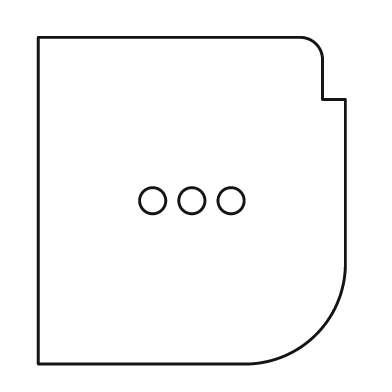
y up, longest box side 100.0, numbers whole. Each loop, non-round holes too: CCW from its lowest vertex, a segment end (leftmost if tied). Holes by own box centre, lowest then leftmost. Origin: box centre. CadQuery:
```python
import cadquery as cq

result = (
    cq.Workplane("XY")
    .moveTo(-47.0, -50.0)
    .lineTo(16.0, -50.0)
    .threePointArc((38.0, -41.0), (47.0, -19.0))
    .lineTo(47.0, 31.0)
    .lineTo(40.0, 31.0)
    .lineTo(40.0, 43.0)
    .threePointArc((38.0, 48.0), (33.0, 50.0))
    .lineTo(-47.0, 50.0)
    .close()
    .moveTo(-12.0, 0.0)
    .circle(4.0)
    .moveTo(0.0, 0.0)
    .circle(4.0)
    .moveTo(12.0, 0.0)
    .circle(4.0)
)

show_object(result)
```